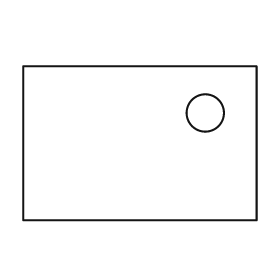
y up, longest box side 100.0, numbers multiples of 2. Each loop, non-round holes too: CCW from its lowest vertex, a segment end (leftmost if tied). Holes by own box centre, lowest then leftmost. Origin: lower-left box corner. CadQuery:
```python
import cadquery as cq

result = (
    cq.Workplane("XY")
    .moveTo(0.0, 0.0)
    .lineTo(100.0, 0.0)
    .lineTo(100.0, 66.0)
    .lineTo(0.0, 66.0)
    .close()
    .moveTo(78.0, 46.0)
    .circle(8.0)
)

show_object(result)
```